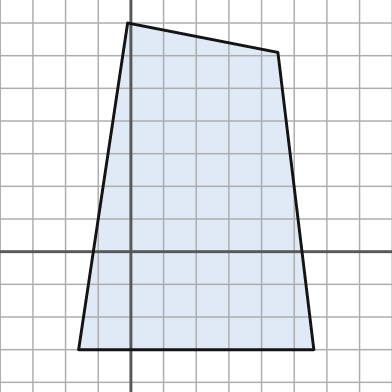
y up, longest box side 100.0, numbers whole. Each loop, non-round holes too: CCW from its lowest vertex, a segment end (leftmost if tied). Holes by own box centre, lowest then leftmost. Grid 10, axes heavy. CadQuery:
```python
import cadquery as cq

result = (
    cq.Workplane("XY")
    .moveTo(-16.0, -30.0)
    .lineTo(56.0, -30.0)
    .lineTo(45.0, 61.0)
    .lineTo(-1.0, 70.0)
    .close()
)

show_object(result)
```